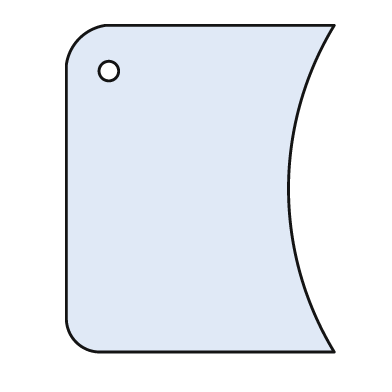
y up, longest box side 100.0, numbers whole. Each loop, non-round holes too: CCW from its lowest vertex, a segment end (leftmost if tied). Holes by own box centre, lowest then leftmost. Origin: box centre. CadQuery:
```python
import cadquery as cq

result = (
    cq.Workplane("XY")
    .moveTo(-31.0, -50.0)
    .lineTo(41.0, -50.0)
    .threePointArc((27.0, 0.0), (41.0, 50.0))
    .lineTo(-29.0, 50.0)
    .threePointArc((-37.0, 46.0), (-41.0, 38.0))
    .lineTo(-41.0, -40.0)
    .threePointArc((-38.0, -47.0), (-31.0, -50.0))
    .close()
    .moveTo(-28.0, 36.0)
    .circle(3.0)
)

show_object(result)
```